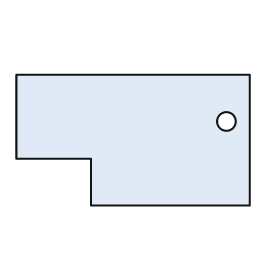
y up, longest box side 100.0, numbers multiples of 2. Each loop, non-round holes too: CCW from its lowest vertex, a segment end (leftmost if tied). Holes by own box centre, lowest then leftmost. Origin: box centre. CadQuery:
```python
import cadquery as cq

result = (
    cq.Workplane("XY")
    .moveTo(-18.0, -28.0)
    .lineTo(50.0, -28.0)
    .lineTo(50.0, 28.0)
    .lineTo(-50.0, 28.0)
    .lineTo(-50.0, -8.0)
    .lineTo(-18.0, -8.0)
    .close()
    .moveTo(40.0, 8.0)
    .circle(4.0)
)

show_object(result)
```